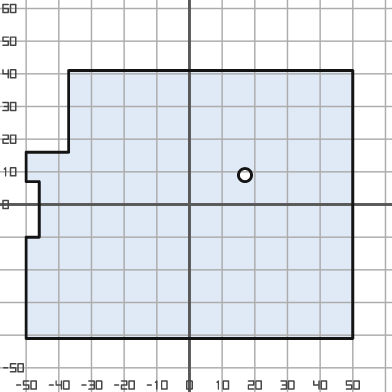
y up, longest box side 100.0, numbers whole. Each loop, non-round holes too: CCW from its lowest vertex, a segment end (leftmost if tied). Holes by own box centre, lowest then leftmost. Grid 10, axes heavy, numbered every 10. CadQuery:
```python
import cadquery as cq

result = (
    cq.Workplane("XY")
    .moveTo(-50.0, -41.0)
    .lineTo(50.0, -41.0)
    .lineTo(50.0, 41.0)
    .lineTo(-37.0, 41.0)
    .lineTo(-37.0, 16.0)
    .lineTo(-50.0, 16.0)
    .lineTo(-50.0, 7.0)
    .lineTo(-46.0, 7.0)
    .lineTo(-46.0, -10.0)
    .lineTo(-50.0, -10.0)
    .close()
    .moveTo(17.0, 9.0)
    .circle(2.0)
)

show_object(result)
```